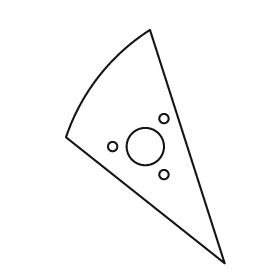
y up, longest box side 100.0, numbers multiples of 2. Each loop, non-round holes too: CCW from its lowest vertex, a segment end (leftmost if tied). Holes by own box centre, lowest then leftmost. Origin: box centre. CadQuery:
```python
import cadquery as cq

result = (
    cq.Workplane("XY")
    .moveTo(34.0, -50.0)
    .lineTo(2.0, 50.0)
    .threePointArc((-20.0, 30.0), (-34.0, 4.0))
    .close()
    .moveTo(8.0, -12.0)
    .circle(2.0)
    .moveTo(-14.0, 0.0)
    .circle(2.0)
    .moveTo(0.0, 0.0)
    .circle(8.0)
    .moveTo(8.0, 12.0)
    .circle(2.0)
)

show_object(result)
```